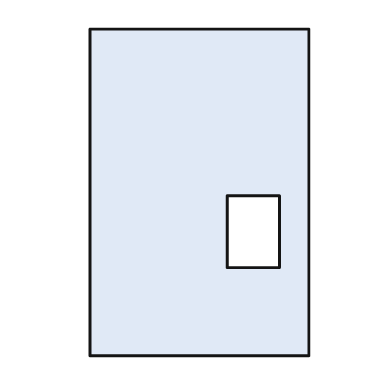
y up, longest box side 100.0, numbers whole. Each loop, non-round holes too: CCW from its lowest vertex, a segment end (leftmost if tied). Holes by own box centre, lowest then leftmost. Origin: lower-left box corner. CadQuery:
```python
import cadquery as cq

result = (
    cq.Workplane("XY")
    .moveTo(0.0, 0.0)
    .lineTo(67.0, 0.0)
    .lineTo(67.0, 100.0)
    .lineTo(0.0, 100.0)
    .close()
    .moveTo(42.0, 27.0)
    .lineTo(58.0, 27.0)
    .lineTo(58.0, 49.0)
    .lineTo(42.0, 49.0)
    .close()
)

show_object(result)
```